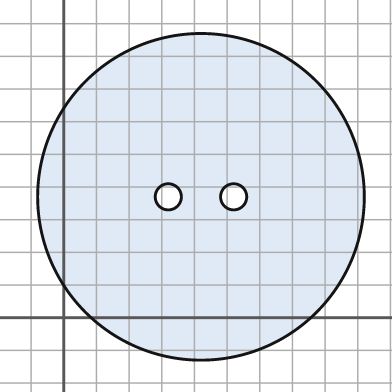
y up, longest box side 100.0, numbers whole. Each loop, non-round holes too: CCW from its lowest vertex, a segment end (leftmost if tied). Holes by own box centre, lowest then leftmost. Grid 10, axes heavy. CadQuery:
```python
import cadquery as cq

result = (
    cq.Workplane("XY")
    .moveTo(42.0, 37.0)
    .circle(50.0)
    .moveTo(32.0, 37.0)
    .circle(4.0)
    .moveTo(52.0, 37.0)
    .circle(4.0)
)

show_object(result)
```